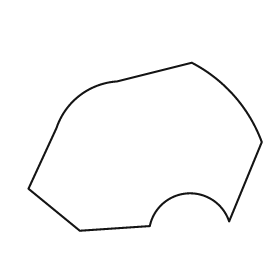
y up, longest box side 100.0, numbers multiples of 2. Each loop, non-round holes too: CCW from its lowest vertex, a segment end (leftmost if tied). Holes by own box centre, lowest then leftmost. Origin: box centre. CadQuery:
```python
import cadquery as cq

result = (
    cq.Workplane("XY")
    .moveTo(-28.0, -36.0)
    .lineTo(2.0, -34.0)
    .threePointArc((18.0, -20.0), (36.0, -32.0))
    .lineTo(50.0, 2.0)
    .threePointArc((38.0, 22.0), (20.0, 36.0))
    .lineTo(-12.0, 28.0)
    .threePointArc((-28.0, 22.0), (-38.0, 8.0))
    .lineTo(-50.0, -18.0)
    .close()
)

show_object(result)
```